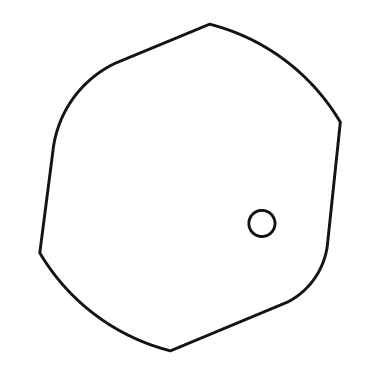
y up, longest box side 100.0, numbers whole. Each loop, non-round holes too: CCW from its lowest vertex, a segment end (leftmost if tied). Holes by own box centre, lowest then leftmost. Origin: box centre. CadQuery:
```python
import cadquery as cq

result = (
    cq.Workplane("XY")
    .moveTo(-6.0, -50.0)
    .lineTo(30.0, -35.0)
    .threePointArc((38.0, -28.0), (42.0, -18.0))
    .lineTo(46.0, 20.0)
    .threePointArc((29.0, 39.0), (6.0, 50.0))
    .lineTo(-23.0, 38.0)
    .threePointArc((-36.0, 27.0), (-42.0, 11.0))
    .lineTo(-46.0, -20.0)
    .threePointArc((-29.0, -39.0), (-6.0, -50.0))
    .close()
    .moveTo(22.0, -11.0)
    .circle(4.0)
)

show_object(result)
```